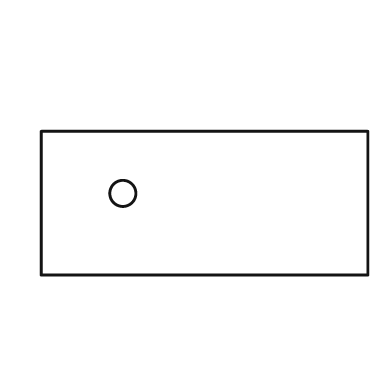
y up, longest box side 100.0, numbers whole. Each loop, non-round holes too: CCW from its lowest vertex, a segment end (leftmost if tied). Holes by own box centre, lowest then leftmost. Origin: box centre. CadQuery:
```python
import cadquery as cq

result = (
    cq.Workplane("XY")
    .moveTo(-50.0, -22.0)
    .lineTo(50.0, -22.0)
    .lineTo(50.0, 22.0)
    .lineTo(-50.0, 22.0)
    .close()
    .moveTo(-25.0, 3.0)
    .circle(4.0)
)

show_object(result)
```